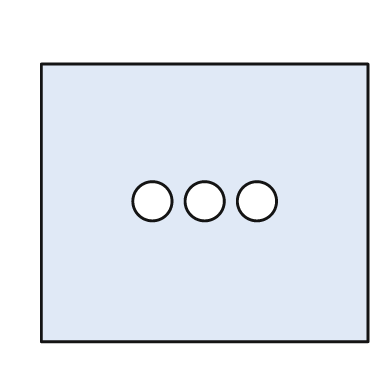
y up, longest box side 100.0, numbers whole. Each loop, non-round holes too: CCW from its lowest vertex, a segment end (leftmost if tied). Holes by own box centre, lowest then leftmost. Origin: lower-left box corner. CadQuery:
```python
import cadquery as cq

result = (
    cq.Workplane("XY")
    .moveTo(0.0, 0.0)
    .lineTo(100.0, 0.0)
    .lineTo(100.0, 85.0)
    .lineTo(0.0, 85.0)
    .close()
    .moveTo(34.0, 43.0)
    .circle(6.0)
    .moveTo(50.0, 43.0)
    .circle(6.0)
    .moveTo(66.0, 43.0)
    .circle(6.0)
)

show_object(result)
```